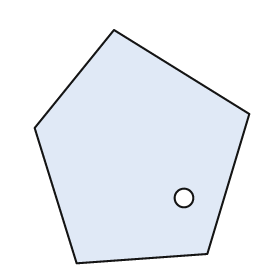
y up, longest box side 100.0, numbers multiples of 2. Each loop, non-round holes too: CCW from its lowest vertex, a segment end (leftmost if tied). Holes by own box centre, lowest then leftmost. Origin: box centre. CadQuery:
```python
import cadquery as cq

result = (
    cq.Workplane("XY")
    .moveTo(-28.0, -50.0)
    .lineTo(28.0, -46.0)
    .lineTo(46.0, 14.0)
    .lineTo(-12.0, 50.0)
    .lineTo(-46.0, 8.0)
    .close()
    .moveTo(18.0, -22.0)
    .circle(4.0)
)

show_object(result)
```